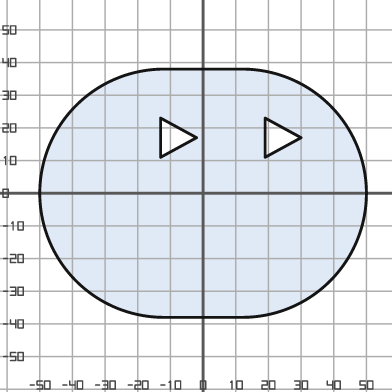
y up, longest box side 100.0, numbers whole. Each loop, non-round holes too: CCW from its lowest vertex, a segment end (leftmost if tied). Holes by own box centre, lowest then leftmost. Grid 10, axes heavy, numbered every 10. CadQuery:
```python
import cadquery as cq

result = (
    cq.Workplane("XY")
    .moveTo(-12.0, -38.0)
    .lineTo(12.0, -38.0)
    .threePointArc((50.0, 0.0), (12.0, 38.0))
    .lineTo(-12.0, 38.0)
    .threePointArc((-50.0, 0.0), (-12.0, -38.0))
    .close()
    .moveTo(-13.0, 11.0)
    .lineTo(-2.0, 17.0)
    .lineTo(-13.0, 23.0)
    .close()
    .moveTo(19.0, 11.0)
    .lineTo(30.0, 17.0)
    .lineTo(19.0, 23.0)
    .close()
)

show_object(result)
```